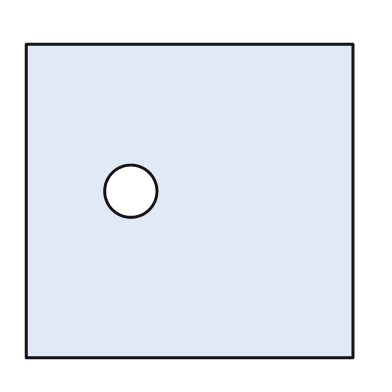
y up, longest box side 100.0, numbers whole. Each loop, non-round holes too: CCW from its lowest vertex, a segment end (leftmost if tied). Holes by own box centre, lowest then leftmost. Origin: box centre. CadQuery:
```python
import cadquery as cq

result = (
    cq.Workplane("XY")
    .moveTo(-50.0, -48.0)
    .lineTo(50.0, -48.0)
    .lineTo(50.0, 48.0)
    .lineTo(-50.0, 48.0)
    .close()
    .moveTo(-18.0, 3.0)
    .circle(8.0)
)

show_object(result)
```